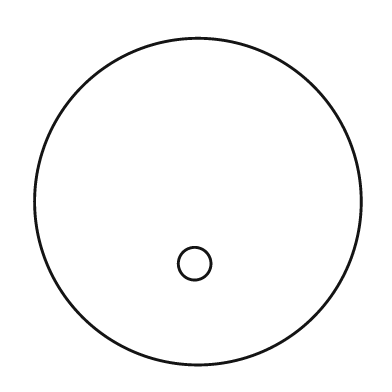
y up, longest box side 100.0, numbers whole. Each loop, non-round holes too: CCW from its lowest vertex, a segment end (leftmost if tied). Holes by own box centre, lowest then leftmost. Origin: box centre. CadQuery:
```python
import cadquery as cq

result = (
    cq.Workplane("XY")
    .moveTo(0.0, 0.0)
    .circle(50.0)
    .moveTo(-1.0, -19.0)
    .circle(5.0)
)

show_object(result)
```